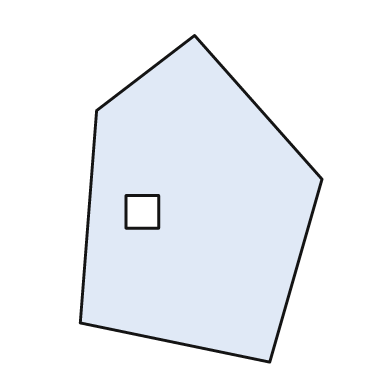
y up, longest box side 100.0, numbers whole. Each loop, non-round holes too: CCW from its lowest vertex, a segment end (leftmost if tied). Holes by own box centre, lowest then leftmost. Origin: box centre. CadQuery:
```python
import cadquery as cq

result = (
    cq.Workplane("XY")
    .moveTo(21.0, -50.0)
    .lineTo(37.0, 6.0)
    .lineTo(-2.0, 50.0)
    .lineTo(-32.0, 27.0)
    .lineTo(-37.0, -38.0)
    .close()
    .moveTo(-23.0, -9.0)
    .lineTo(-13.0, -9.0)
    .lineTo(-13.0, 1.0)
    .lineTo(-23.0, 1.0)
    .close()
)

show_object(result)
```